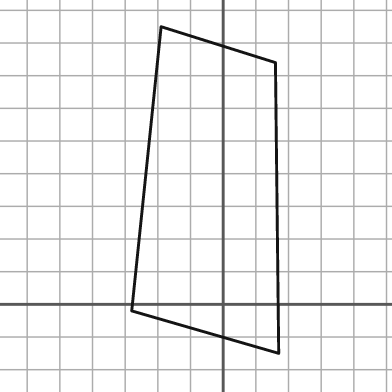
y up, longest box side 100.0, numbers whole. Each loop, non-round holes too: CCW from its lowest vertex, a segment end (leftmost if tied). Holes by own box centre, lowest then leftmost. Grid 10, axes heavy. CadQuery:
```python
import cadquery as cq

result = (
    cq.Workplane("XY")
    .moveTo(17.0, -15.0)
    .lineTo(16.0, 74.0)
    .lineTo(-19.0, 85.0)
    .lineTo(-28.0, -2.0)
    .close()
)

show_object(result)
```